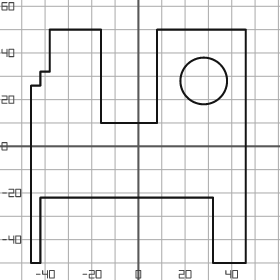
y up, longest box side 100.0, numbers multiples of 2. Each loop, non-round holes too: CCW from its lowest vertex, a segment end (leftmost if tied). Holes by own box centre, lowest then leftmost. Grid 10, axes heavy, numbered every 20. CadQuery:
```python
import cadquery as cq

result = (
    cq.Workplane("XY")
    .moveTo(-46.0, -50.0)
    .lineTo(-42.0, -50.0)
    .lineTo(-42.0, -22.0)
    .lineTo(32.0, -22.0)
    .lineTo(32.0, -50.0)
    .lineTo(46.0, -50.0)
    .lineTo(46.0, 50.0)
    .lineTo(8.0, 50.0)
    .lineTo(8.0, 10.0)
    .lineTo(-16.0, 10.0)
    .lineTo(-16.0, 50.0)
    .lineTo(-38.0, 50.0)
    .lineTo(-38.0, 32.0)
    .lineTo(-42.0, 32.0)
    .lineTo(-42.0, 26.0)
    .lineTo(-46.0, 26.0)
    .close()
    .moveTo(28.0, 28.0)
    .circle(10.0)
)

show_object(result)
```